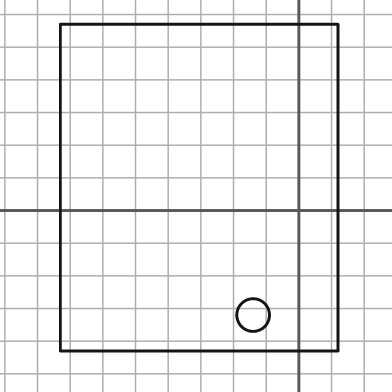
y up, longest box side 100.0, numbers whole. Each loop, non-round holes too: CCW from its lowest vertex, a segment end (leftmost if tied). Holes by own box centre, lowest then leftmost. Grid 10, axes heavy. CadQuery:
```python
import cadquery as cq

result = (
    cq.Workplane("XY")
    .moveTo(-73.0, -43.0)
    .lineTo(12.0, -43.0)
    .lineTo(12.0, 57.0)
    .lineTo(-73.0, 57.0)
    .close()
    .moveTo(-14.0, -32.0)
    .circle(5.0)
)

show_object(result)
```